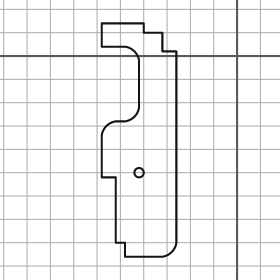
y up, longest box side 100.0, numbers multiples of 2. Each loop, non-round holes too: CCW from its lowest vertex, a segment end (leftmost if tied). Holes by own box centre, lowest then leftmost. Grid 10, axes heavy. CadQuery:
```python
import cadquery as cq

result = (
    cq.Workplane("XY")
    .moveTo(-48.0, -86.0)
    .lineTo(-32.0, -86.0)
    .threePointArc((-28.0, -84.0), (-26.0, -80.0))
    .lineTo(-26.0, 2.0)
    .lineTo(-32.0, 2.0)
    .lineTo(-32.0, 10.0)
    .lineTo(-40.0, 10.0)
    .lineTo(-40.0, 14.0)
    .lineTo(-58.0, 14.0)
    .lineTo(-58.0, 4.0)
    .lineTo(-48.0, 4.0)
    .threePointArc((-44.0, 2.0), (-42.0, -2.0))
    .lineTo(-42.0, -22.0)
    .threePointArc((-44.0, -26.0), (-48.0, -28.0))
    .lineTo(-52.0, -28.0)
    .threePointArc((-56.0, -30.0), (-58.0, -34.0))
    .lineTo(-58.0, -52.0)
    .lineTo(-52.0, -52.0)
    .lineTo(-52.0, -80.0)
    .lineTo(-48.0, -80.0)
    .close()
    .moveTo(-42.0, -50.0)
    .circle(2.0)
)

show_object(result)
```